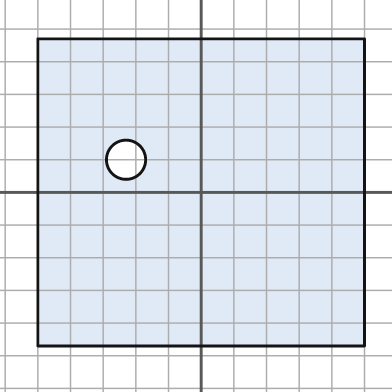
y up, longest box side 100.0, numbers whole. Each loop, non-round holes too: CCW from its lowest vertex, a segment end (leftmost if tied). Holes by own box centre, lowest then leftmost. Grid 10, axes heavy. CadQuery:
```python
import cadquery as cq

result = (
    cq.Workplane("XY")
    .moveTo(-50.0, -47.0)
    .lineTo(50.0, -47.0)
    .lineTo(50.0, 47.0)
    .lineTo(-50.0, 47.0)
    .close()
    .moveTo(-23.0, 10.0)
    .circle(6.0)
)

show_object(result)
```